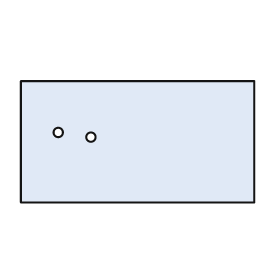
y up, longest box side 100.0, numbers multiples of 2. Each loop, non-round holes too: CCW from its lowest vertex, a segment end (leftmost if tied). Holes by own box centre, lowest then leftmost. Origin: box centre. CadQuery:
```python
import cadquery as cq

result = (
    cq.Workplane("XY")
    .moveTo(-50.0, -26.0)
    .lineTo(50.0, -26.0)
    .lineTo(50.0, 26.0)
    .lineTo(-50.0, 26.0)
    .close()
    .moveTo(-20.0, 2.0)
    .circle(2.0)
    .moveTo(-34.0, 4.0)
    .circle(2.0)
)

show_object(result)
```